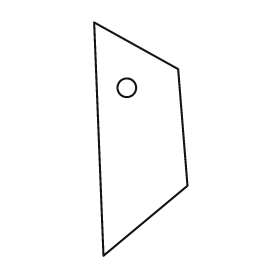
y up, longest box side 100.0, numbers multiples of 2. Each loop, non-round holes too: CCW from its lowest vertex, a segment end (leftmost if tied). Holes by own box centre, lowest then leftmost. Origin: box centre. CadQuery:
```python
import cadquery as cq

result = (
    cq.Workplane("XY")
    .moveTo(-16.0, -50.0)
    .lineTo(20.0, -20.0)
    .lineTo(16.0, 30.0)
    .lineTo(-20.0, 50.0)
    .close()
    .moveTo(-6.0, 22.0)
    .circle(4.0)
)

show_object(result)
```